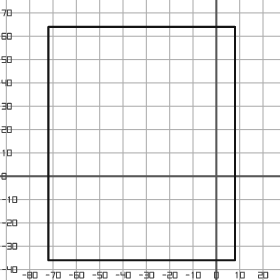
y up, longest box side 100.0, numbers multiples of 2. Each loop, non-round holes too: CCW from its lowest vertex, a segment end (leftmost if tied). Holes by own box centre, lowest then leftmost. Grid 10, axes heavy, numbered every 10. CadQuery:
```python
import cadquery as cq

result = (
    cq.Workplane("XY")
    .moveTo(-72.0, -36.0)
    .lineTo(8.0, -36.0)
    .lineTo(8.0, 64.0)
    .lineTo(-72.0, 64.0)
    .close()
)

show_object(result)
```